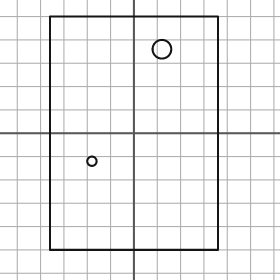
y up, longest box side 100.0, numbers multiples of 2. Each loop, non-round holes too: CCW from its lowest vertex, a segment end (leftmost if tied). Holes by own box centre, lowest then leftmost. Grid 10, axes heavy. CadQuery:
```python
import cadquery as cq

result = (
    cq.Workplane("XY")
    .moveTo(-36.0, -50.0)
    .lineTo(36.0, -50.0)
    .lineTo(36.0, 50.0)
    .lineTo(-36.0, 50.0)
    .close()
    .moveTo(-18.0, -12.0)
    .circle(2.0)
    .moveTo(12.0, 36.0)
    .circle(4.0)
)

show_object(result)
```